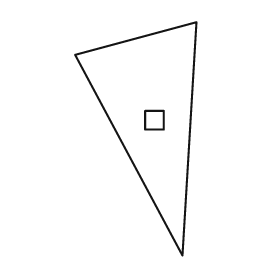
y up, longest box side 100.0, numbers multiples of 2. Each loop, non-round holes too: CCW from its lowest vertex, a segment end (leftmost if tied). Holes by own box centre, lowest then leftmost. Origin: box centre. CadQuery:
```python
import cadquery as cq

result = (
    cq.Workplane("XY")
    .moveTo(20.0, -50.0)
    .lineTo(26.0, 50.0)
    .lineTo(-26.0, 36.0)
    .close()
    .moveTo(4.0, 4.0)
    .lineTo(12.0, 4.0)
    .lineTo(12.0, 12.0)
    .lineTo(4.0, 12.0)
    .close()
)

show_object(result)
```